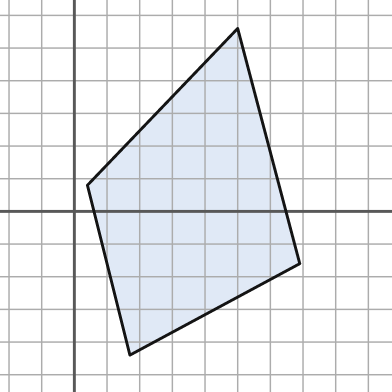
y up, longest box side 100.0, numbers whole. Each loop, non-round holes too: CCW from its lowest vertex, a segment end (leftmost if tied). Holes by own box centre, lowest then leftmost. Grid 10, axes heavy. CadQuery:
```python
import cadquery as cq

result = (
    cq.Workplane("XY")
    .moveTo(17.0, -44.0)
    .lineTo(69.0, -16.0)
    .lineTo(50.0, 56.0)
    .lineTo(4.0, 8.0)
    .close()
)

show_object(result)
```